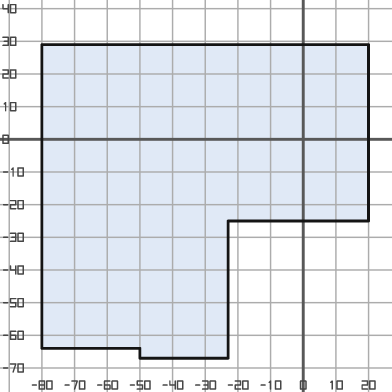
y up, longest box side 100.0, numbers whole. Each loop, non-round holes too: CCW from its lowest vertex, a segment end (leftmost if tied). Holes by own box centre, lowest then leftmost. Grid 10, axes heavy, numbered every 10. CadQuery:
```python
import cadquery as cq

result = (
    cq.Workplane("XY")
    .moveTo(-50.0, -67.0)
    .lineTo(-23.0, -67.0)
    .lineTo(-23.0, -25.0)
    .lineTo(20.0, -25.0)
    .lineTo(20.0, 29.0)
    .lineTo(-80.0, 29.0)
    .lineTo(-80.0, -64.0)
    .lineTo(-50.0, -64.0)
    .close()
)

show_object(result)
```